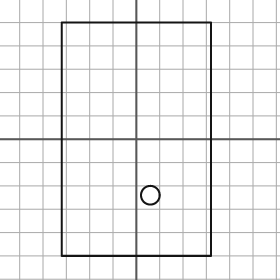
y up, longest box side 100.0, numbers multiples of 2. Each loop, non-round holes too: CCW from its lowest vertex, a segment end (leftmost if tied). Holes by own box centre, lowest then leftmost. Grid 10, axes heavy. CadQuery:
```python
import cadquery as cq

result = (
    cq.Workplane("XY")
    .moveTo(-32.0, -50.0)
    .lineTo(32.0, -50.0)
    .lineTo(32.0, 50.0)
    .lineTo(-32.0, 50.0)
    .close()
    .moveTo(6.0, -24.0)
    .circle(4.0)
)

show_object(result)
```